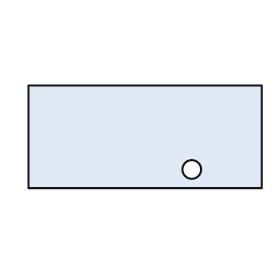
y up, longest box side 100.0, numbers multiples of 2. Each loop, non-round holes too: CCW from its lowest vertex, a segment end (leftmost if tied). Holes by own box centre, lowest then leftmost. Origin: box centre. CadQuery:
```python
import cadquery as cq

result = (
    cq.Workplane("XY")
    .moveTo(-50.0, -22.0)
    .lineTo(50.0, -22.0)
    .lineTo(50.0, 22.0)
    .lineTo(-50.0, 22.0)
    .close()
    .moveTo(20.0, -14.0)
    .circle(4.0)
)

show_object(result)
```